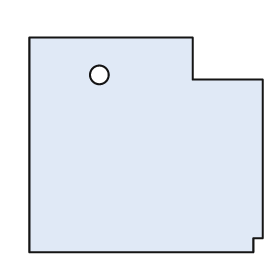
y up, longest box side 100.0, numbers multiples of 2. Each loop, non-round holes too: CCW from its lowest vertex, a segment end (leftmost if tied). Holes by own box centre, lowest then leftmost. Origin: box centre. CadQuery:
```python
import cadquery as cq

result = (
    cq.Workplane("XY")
    .moveTo(-50.0, -46.0)
    .lineTo(46.0, -46.0)
    .lineTo(46.0, -40.0)
    .lineTo(50.0, -40.0)
    .lineTo(50.0, 28.0)
    .lineTo(20.0, 28.0)
    .lineTo(20.0, 46.0)
    .lineTo(-50.0, 46.0)
    .close()
    .moveTo(-20.0, 30.0)
    .circle(4.0)
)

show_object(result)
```